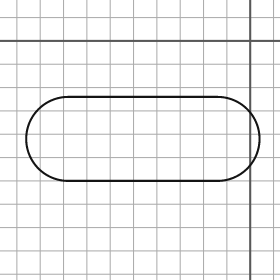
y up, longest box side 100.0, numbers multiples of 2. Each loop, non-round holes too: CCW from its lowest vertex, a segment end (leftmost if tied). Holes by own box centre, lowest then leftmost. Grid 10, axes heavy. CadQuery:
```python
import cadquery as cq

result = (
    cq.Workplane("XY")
    .moveTo(-78.0, -60.0)
    .lineTo(-14.0, -60.0)
    .threePointArc((4.0, -42.0), (-14.0, -24.0))
    .lineTo(-78.0, -24.0)
    .threePointArc((-96.0, -42.0), (-78.0, -60.0))
    .close()
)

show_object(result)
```